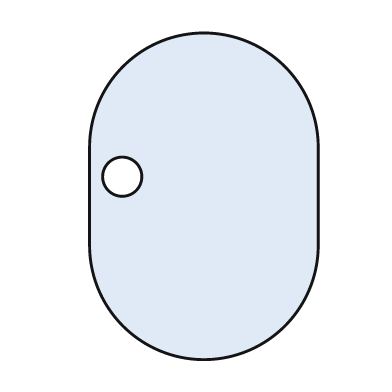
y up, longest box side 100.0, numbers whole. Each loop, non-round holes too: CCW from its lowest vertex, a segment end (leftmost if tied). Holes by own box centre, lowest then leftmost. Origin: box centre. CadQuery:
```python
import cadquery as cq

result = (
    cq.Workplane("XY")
    .moveTo(-35.0, -15.0)
    .threePointArc((0.0, -50.0), (35.0, -15.0))
    .lineTo(35.0, 15.0)
    .threePointArc((0.0, 50.0), (-35.0, 15.0))
    .close()
    .moveTo(-25.0, 6.0)
    .circle(6.0)
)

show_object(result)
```